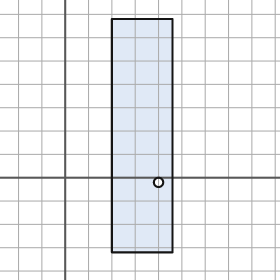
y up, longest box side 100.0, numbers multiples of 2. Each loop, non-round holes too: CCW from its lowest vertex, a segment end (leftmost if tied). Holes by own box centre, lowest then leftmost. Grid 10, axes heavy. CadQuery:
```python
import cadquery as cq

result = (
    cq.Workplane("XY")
    .moveTo(20.0, -32.0)
    .lineTo(46.0, -32.0)
    .lineTo(46.0, 68.0)
    .lineTo(20.0, 68.0)
    .close()
    .moveTo(40.0, -2.0)
    .circle(2.0)
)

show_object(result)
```